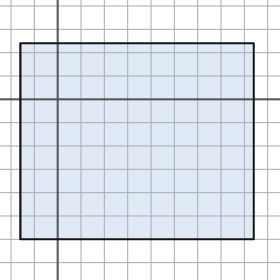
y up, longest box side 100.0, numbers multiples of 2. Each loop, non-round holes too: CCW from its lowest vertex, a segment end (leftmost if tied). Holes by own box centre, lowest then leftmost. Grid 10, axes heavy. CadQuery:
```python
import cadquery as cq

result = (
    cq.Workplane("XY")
    .moveTo(-16.0, -60.0)
    .lineTo(84.0, -60.0)
    .lineTo(84.0, 24.0)
    .lineTo(-16.0, 24.0)
    .close()
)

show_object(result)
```